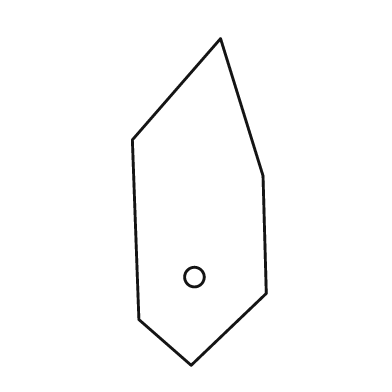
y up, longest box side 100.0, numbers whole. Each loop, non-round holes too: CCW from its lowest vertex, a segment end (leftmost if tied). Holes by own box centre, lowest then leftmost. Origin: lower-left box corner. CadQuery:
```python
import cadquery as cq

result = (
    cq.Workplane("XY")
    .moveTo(18.0, 0.0)
    .lineTo(41.0, 22.0)
    .lineTo(40.0, 58.0)
    .lineTo(27.0, 100.0)
    .lineTo(0.0, 69.0)
    .lineTo(2.0, 14.0)
    .close()
    .moveTo(19.0, 27.0)
    .circle(3.0)
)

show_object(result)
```